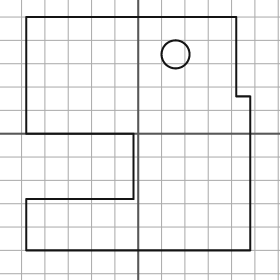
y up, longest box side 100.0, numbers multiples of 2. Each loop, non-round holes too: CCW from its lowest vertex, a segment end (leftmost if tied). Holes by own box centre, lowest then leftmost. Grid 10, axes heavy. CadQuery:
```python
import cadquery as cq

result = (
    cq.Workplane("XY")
    .moveTo(-48.0, -50.0)
    .lineTo(48.0, -50.0)
    .lineTo(48.0, 16.0)
    .lineTo(42.0, 16.0)
    .lineTo(42.0, 50.0)
    .lineTo(-48.0, 50.0)
    .lineTo(-48.0, 0.0)
    .lineTo(-2.0, 0.0)
    .lineTo(-2.0, -28.0)
    .lineTo(-48.0, -28.0)
    .close()
    .moveTo(16.0, 34.0)
    .circle(6.0)
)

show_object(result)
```